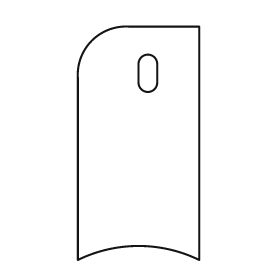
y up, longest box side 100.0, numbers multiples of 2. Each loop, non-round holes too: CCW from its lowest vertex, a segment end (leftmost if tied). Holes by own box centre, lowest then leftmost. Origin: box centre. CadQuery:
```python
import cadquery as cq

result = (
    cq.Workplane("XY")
    .moveTo(-26.0, -50.0)
    .threePointArc((0.0, -44.0), (26.0, -50.0))
    .lineTo(26.0, 50.0)
    .lineTo(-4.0, 50.0)
    .threePointArc((-20.0, 44.0), (-26.0, 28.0))
    .close()
    .moveTo(0.0, 26.0)
    .threePointArc((4.0, 22.0), (8.0, 26.0))
    .lineTo(8.0, 34.0)
    .threePointArc((4.0, 38.0), (0.0, 34.0))
    .close()
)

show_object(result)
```